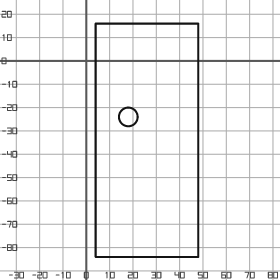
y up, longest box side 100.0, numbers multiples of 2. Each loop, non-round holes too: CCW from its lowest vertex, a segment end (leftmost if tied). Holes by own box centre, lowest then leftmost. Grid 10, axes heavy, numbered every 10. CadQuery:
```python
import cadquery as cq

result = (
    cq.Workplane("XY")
    .moveTo(4.0, -84.0)
    .lineTo(48.0, -84.0)
    .lineTo(48.0, 16.0)
    .lineTo(4.0, 16.0)
    .close()
    .moveTo(18.0, -24.0)
    .circle(4.0)
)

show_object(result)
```